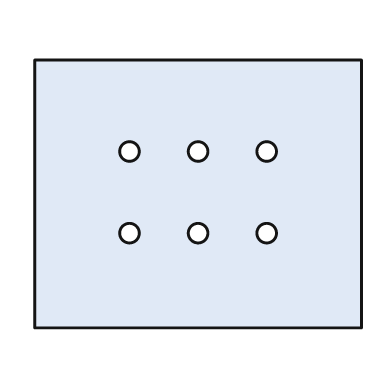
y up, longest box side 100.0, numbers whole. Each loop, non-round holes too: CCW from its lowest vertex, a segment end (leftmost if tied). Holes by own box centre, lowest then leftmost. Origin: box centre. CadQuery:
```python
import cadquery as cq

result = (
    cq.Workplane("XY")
    .moveTo(-50.0, -41.0)
    .lineTo(50.0, -41.0)
    .lineTo(50.0, 41.0)
    .lineTo(-50.0, 41.0)
    .close()
    .moveTo(-21.0, -12.0)
    .circle(3.0)
    .moveTo(0.0, -12.0)
    .circle(3.0)
    .moveTo(21.0, -12.0)
    .circle(3.0)
    .moveTo(-21.0, 13.0)
    .circle(3.0)
    .moveTo(0.0, 13.0)
    .circle(3.0)
    .moveTo(21.0, 13.0)
    .circle(3.0)
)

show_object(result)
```